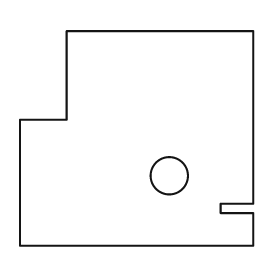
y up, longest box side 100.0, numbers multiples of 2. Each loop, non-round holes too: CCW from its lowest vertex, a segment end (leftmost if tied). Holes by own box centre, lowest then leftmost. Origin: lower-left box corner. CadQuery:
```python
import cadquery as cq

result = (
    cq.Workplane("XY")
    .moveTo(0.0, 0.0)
    .lineTo(100.0, 0.0)
    .lineTo(100.0, 14.0)
    .lineTo(86.0, 14.0)
    .lineTo(86.0, 18.0)
    .lineTo(100.0, 18.0)
    .lineTo(100.0, 92.0)
    .lineTo(20.0, 92.0)
    .lineTo(20.0, 54.0)
    .lineTo(0.0, 54.0)
    .close()
    .moveTo(64.0, 30.0)
    .circle(8.0)
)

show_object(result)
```